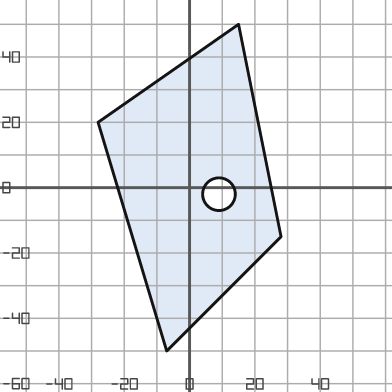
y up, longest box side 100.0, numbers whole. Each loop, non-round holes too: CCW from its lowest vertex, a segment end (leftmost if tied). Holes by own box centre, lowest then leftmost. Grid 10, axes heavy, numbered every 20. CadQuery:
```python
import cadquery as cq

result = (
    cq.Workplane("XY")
    .moveTo(-7.0, -50.0)
    .lineTo(28.0, -15.0)
    .lineTo(15.0, 50.0)
    .lineTo(-28.0, 20.0)
    .close()
    .moveTo(9.0, -2.0)
    .circle(5.0)
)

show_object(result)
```